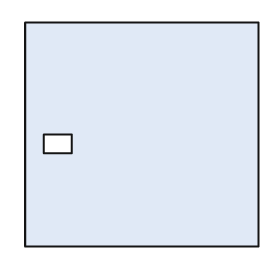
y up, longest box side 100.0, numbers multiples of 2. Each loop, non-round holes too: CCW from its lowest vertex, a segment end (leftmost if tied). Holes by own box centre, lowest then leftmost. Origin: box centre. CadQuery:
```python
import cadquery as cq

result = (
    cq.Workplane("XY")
    .moveTo(-50.0, -48.0)
    .lineTo(50.0, -48.0)
    .lineTo(50.0, 48.0)
    .lineTo(-50.0, 48.0)
    .close()
    .moveTo(-42.0, -8.0)
    .lineTo(-30.0, -8.0)
    .lineTo(-30.0, 0.0)
    .lineTo(-42.0, 0.0)
    .close()
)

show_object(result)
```